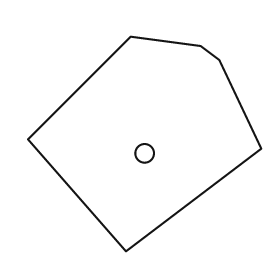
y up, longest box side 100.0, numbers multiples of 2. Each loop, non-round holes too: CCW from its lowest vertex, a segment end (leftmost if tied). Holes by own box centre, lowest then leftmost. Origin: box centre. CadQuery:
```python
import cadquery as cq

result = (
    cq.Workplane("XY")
    .moveTo(-8.0, -46.0)
    .lineTo(50.0, -2.0)
    .lineTo(32.0, 36.0)
    .lineTo(24.0, 42.0)
    .lineTo(-6.0, 46.0)
    .lineTo(-50.0, 2.0)
    .close()
    .moveTo(0.0, -4.0)
    .circle(4.0)
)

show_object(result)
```